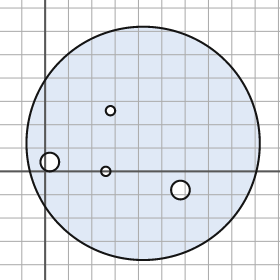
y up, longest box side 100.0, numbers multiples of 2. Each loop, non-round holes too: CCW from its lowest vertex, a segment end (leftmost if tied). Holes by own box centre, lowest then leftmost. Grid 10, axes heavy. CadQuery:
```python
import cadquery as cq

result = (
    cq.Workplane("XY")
    .moveTo(42.0, 12.0)
    .circle(50.0)
    .moveTo(58.0, -8.0)
    .circle(4.0)
    .moveTo(26.0, 0.0)
    .circle(2.0)
    .moveTo(2.0, 4.0)
    .circle(4.0)
    .moveTo(28.0, 26.0)
    .circle(2.0)
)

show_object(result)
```